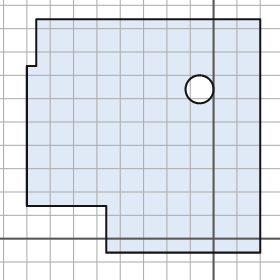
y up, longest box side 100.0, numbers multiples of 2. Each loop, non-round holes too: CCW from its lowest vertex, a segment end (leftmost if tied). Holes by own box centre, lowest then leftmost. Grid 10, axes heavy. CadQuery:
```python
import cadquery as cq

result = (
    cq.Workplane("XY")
    .moveTo(-46.0, -6.0)
    .lineTo(20.0, -6.0)
    .lineTo(20.0, 94.0)
    .lineTo(-76.0, 94.0)
    .lineTo(-76.0, 74.0)
    .lineTo(-80.0, 74.0)
    .lineTo(-80.0, 14.0)
    .lineTo(-46.0, 14.0)
    .close()
    .moveTo(-6.0, 64.0)
    .circle(6.0)
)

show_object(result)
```